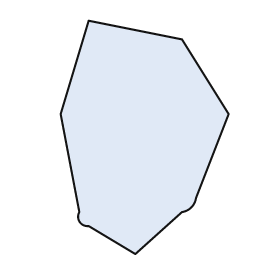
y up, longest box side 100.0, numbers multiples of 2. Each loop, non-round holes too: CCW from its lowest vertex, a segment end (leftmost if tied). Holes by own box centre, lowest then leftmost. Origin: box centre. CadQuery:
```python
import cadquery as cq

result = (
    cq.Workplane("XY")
    .moveTo(-4.0, -50.0)
    .lineTo(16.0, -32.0)
    .threePointArc((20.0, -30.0), (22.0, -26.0))
    .lineTo(36.0, 10.0)
    .lineTo(16.0, 42.0)
    .lineTo(-24.0, 50.0)
    .lineTo(-36.0, 10.0)
    .lineTo(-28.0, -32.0)
    .threePointArc((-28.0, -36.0), (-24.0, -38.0))
    .close()
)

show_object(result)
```